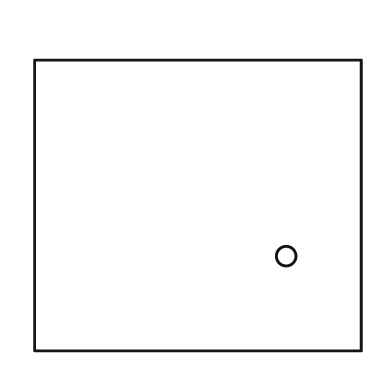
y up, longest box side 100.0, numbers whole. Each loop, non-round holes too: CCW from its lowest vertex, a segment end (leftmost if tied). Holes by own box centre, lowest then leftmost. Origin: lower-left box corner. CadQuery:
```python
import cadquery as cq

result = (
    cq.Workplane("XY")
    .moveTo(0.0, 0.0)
    .lineTo(100.0, 0.0)
    .lineTo(100.0, 89.0)
    .lineTo(0.0, 89.0)
    .close()
    .moveTo(77.0, 29.0)
    .circle(3.0)
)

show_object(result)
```